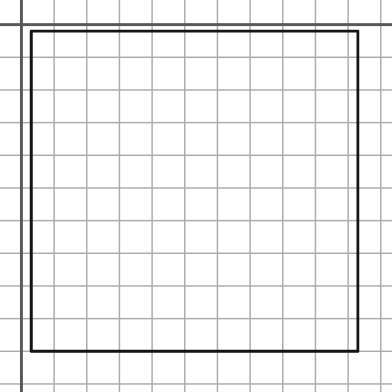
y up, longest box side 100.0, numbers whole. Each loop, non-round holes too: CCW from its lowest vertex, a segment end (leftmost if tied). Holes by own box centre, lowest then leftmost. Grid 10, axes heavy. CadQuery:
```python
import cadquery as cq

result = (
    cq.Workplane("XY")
    .moveTo(3.0, -100.0)
    .lineTo(103.0, -100.0)
    .lineTo(103.0, -2.0)
    .lineTo(3.0, -2.0)
    .close()
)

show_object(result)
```